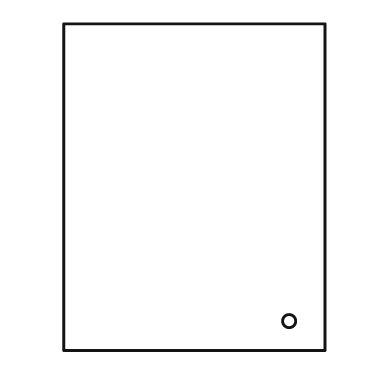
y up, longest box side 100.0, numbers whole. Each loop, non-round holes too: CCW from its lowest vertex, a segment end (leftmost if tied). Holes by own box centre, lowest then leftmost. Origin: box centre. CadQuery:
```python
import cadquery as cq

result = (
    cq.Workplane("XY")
    .moveTo(-40.0, -50.0)
    .lineTo(40.0, -50.0)
    .lineTo(40.0, 50.0)
    .lineTo(-40.0, 50.0)
    .close()
    .moveTo(29.0, -41.0)
    .circle(2.0)
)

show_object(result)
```